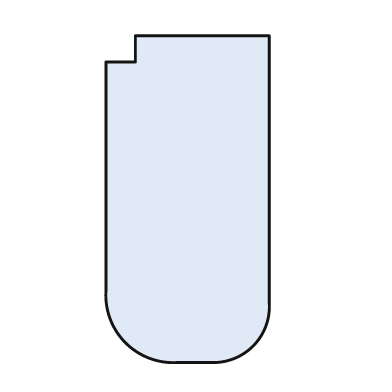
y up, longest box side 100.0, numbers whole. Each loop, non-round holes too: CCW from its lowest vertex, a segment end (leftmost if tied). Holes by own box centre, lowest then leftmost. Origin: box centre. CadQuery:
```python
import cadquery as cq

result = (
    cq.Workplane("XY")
    .moveTo(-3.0, -50.0)
    .lineTo(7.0, -50.0)
    .threePointArc((20.0, -45.0), (25.0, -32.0))
    .lineTo(25.0, 50.0)
    .lineTo(-16.0, 50.0)
    .lineTo(-16.0, 42.0)
    .lineTo(-25.0, 42.0)
    .lineTo(-25.0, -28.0)
    .threePointArc((-19.0, -44.0), (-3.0, -50.0))
    .close()
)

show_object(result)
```